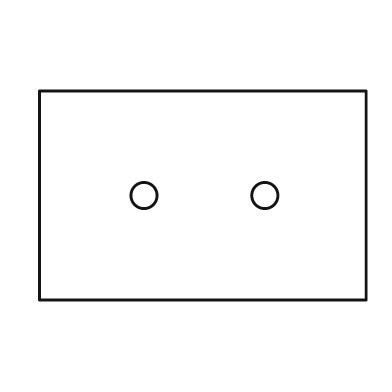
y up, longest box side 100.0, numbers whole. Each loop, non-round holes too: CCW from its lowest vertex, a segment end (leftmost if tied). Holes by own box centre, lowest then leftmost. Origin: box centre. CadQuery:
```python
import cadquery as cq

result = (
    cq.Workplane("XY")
    .moveTo(-50.0, -32.0)
    .lineTo(50.0, -32.0)
    .lineTo(50.0, 32.0)
    .lineTo(-50.0, 32.0)
    .close()
    .moveTo(-18.0, 0.0)
    .circle(4.0)
    .moveTo(19.0, 0.0)
    .circle(4.0)
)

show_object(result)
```